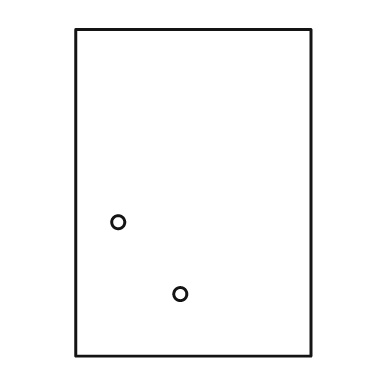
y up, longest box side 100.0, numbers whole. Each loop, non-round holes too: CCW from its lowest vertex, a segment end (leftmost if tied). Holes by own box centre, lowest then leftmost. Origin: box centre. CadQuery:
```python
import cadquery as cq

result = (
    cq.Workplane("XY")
    .moveTo(-36.0, -50.0)
    .lineTo(36.0, -50.0)
    .lineTo(36.0, 50.0)
    .lineTo(-36.0, 50.0)
    .close()
    .moveTo(-4.0, -31.0)
    .circle(2.0)
    .moveTo(-23.0, -9.0)
    .circle(2.0)
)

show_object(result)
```